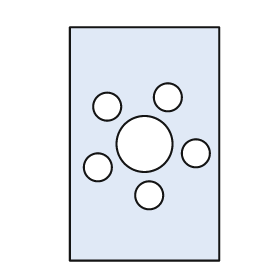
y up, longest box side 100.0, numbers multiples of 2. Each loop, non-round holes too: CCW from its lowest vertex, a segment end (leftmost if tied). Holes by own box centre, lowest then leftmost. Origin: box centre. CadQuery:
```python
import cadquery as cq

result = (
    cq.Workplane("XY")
    .moveTo(-32.0, -50.0)
    .lineTo(32.0, -50.0)
    .lineTo(32.0, 50.0)
    .lineTo(-32.0, 50.0)
    .close()
    .moveTo(2.0, -22.0)
    .circle(6.0)
    .moveTo(-20.0, -10.0)
    .circle(6.0)
    .moveTo(22.0, -4.0)
    .circle(6.0)
    .moveTo(0.0, 0.0)
    .circle(12.0)
    .moveTo(-16.0, 16.0)
    .circle(6.0)
    .moveTo(10.0, 20.0)
    .circle(6.0)
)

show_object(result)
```